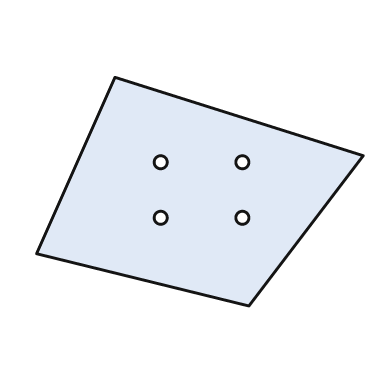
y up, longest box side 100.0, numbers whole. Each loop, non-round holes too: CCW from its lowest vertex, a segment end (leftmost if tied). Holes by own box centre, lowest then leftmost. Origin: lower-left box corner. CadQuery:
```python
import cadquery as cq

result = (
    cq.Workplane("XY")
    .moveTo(65.0, 0.0)
    .lineTo(100.0, 46.0)
    .lineTo(24.0, 70.0)
    .lineTo(0.0, 16.0)
    .close()
    .moveTo(38.0, 27.0)
    .circle(2.0)
    .moveTo(63.0, 27.0)
    .circle(2.0)
    .moveTo(38.0, 44.0)
    .circle(2.0)
    .moveTo(63.0, 44.0)
    .circle(2.0)
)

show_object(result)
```